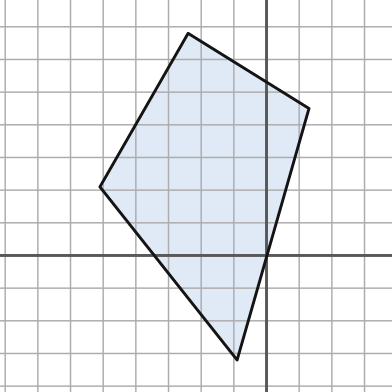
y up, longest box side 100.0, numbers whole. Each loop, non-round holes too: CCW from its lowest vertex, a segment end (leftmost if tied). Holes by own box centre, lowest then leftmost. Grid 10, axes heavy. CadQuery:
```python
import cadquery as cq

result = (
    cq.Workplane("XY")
    .moveTo(-9.0, -32.0)
    .lineTo(13.0, 45.0)
    .lineTo(-24.0, 68.0)
    .lineTo(-51.0, 21.0)
    .close()
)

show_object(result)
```